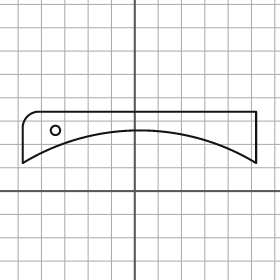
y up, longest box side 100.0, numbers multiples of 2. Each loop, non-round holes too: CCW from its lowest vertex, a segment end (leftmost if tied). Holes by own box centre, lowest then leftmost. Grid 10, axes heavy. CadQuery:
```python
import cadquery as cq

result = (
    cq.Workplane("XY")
    .moveTo(-48.0, 12.0)
    .threePointArc((2.0, 26.0), (52.0, 12.0))
    .lineTo(52.0, 34.0)
    .lineTo(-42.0, 34.0)
    .threePointArc((-46.0, 32.0), (-48.0, 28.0))
    .close()
    .moveTo(-34.0, 26.0)
    .circle(2.0)
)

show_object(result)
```